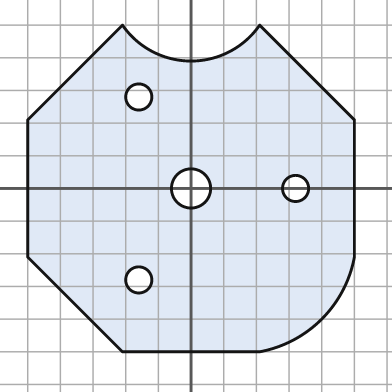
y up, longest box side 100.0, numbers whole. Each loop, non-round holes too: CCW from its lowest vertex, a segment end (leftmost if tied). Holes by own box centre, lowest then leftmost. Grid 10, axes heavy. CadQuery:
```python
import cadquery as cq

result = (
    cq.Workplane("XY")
    .moveTo(-21.0, -50.0)
    .lineTo(21.0, -50.0)
    .threePointArc((40.0, -40.0), (50.0, -21.0))
    .lineTo(50.0, 21.0)
    .lineTo(21.0, 50.0)
    .threePointArc((0.0, 39.0), (-21.0, 50.0))
    .lineTo(-50.0, 21.0)
    .lineTo(-50.0, -21.0)
    .close()
    .moveTo(-16.0, -28.0)
    .circle(4.0)
    .moveTo(0.0, 0.0)
    .circle(6.0)
    .moveTo(32.0, 0.0)
    .circle(4.0)
    .moveTo(-16.0, 28.0)
    .circle(4.0)
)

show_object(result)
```